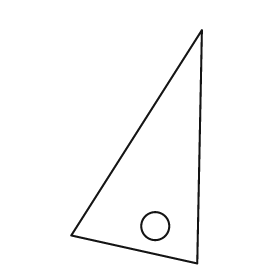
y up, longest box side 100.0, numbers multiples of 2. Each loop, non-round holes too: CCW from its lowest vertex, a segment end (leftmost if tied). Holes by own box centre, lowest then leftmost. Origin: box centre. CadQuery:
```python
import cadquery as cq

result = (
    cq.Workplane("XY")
    .moveTo(26.0, -50.0)
    .lineTo(28.0, 50.0)
    .lineTo(-28.0, -38.0)
    .close()
    .moveTo(8.0, -34.0)
    .circle(6.0)
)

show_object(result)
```